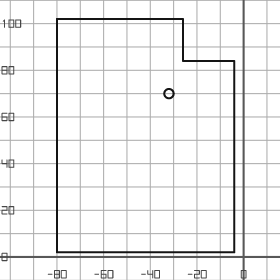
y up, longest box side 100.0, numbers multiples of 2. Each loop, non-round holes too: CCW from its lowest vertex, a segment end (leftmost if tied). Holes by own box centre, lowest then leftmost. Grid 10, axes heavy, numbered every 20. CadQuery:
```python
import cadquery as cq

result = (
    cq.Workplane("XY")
    .moveTo(-80.0, 2.0)
    .lineTo(-4.0, 2.0)
    .lineTo(-4.0, 84.0)
    .lineTo(-26.0, 84.0)
    .lineTo(-26.0, 102.0)
    .lineTo(-80.0, 102.0)
    .close()
    .moveTo(-32.0, 70.0)
    .circle(2.0)
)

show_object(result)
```